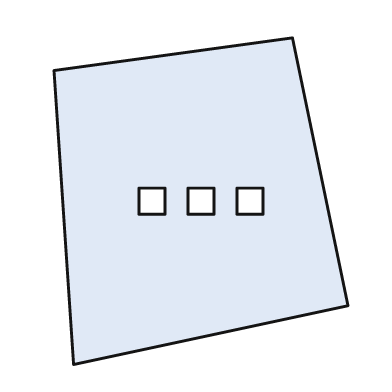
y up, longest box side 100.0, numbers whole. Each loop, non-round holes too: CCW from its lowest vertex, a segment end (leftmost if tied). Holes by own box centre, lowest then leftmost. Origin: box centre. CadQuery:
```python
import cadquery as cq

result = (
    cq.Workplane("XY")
    .moveTo(-39.0, -50.0)
    .lineTo(45.0, -32.0)
    .lineTo(28.0, 50.0)
    .lineTo(-45.0, 40.0)
    .close()
    .moveTo(-19.0, -4.0)
    .lineTo(-11.0, -4.0)
    .lineTo(-11.0, 4.0)
    .lineTo(-19.0, 4.0)
    .close()
    .moveTo(-4.0, -4.0)
    .lineTo(4.0, -4.0)
    .lineTo(4.0, 4.0)
    .lineTo(-4.0, 4.0)
    .close()
    .moveTo(11.0, -4.0)
    .lineTo(19.0, -4.0)
    .lineTo(19.0, 4.0)
    .lineTo(11.0, 4.0)
    .close()
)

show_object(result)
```